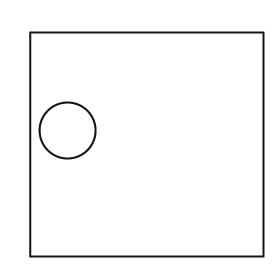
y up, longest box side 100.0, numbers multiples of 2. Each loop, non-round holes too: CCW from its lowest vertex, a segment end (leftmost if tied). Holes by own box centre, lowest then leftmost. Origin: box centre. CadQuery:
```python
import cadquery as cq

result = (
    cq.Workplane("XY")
    .moveTo(-50.0, -48.0)
    .lineTo(50.0, -48.0)
    .lineTo(50.0, 48.0)
    .lineTo(-50.0, 48.0)
    .close()
    .moveTo(-34.0, 6.0)
    .circle(12.0)
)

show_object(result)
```